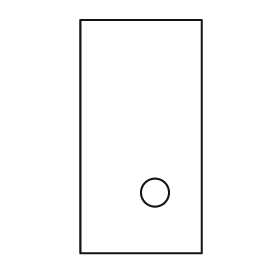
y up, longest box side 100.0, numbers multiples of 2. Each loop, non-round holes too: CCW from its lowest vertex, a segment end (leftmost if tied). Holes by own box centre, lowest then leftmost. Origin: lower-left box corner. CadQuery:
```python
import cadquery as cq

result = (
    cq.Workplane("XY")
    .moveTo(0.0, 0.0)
    .lineTo(52.0, 0.0)
    .lineTo(52.0, 100.0)
    .lineTo(0.0, 100.0)
    .close()
    .moveTo(32.0, 26.0)
    .circle(6.0)
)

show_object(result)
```